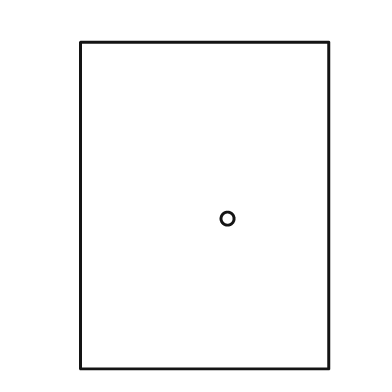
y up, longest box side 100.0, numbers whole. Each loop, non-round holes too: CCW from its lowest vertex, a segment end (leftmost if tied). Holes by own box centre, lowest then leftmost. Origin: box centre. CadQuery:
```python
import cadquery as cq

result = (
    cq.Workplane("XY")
    .moveTo(-38.0, -50.0)
    .lineTo(38.0, -50.0)
    .lineTo(38.0, 50.0)
    .lineTo(-38.0, 50.0)
    .close()
    .moveTo(7.0, -4.0)
    .circle(2.0)
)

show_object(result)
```